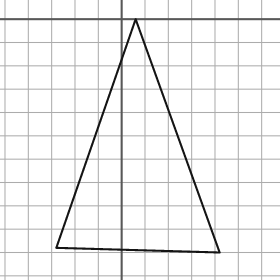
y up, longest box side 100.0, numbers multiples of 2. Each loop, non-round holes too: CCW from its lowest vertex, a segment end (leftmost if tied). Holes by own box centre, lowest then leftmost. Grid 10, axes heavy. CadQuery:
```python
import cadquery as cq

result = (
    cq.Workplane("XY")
    .moveTo(42.0, -100.0)
    .lineTo(6.0, 0.0)
    .lineTo(-28.0, -98.0)
    .close()
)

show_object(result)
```